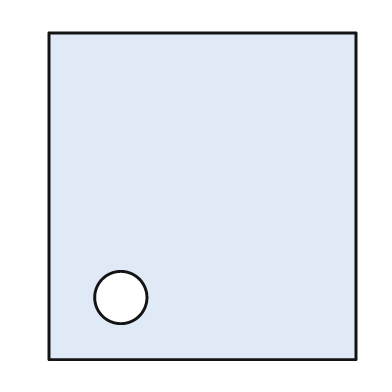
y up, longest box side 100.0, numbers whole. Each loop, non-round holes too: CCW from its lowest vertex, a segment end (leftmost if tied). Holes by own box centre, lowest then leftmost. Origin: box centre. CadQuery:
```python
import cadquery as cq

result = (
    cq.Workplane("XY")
    .moveTo(-47.0, -50.0)
    .lineTo(47.0, -50.0)
    .lineTo(47.0, 50.0)
    .lineTo(-47.0, 50.0)
    .close()
    .moveTo(-25.0, -31.0)
    .circle(8.0)
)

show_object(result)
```